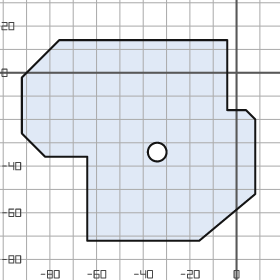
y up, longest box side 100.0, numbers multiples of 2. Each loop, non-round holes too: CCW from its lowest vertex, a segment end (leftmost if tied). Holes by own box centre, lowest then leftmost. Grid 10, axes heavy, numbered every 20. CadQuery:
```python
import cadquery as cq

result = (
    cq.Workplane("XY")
    .moveTo(-64.0, -72.0)
    .lineTo(-16.0, -72.0)
    .lineTo(8.0, -52.0)
    .lineTo(8.0, -20.0)
    .lineTo(4.0, -16.0)
    .lineTo(-4.0, -16.0)
    .lineTo(-4.0, 14.0)
    .lineTo(-76.0, 14.0)
    .lineTo(-92.0, -2.0)
    .lineTo(-92.0, -26.0)
    .lineTo(-82.0, -36.0)
    .lineTo(-64.0, -36.0)
    .close()
    .moveTo(-34.0, -34.0)
    .circle(4.0)
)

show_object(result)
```